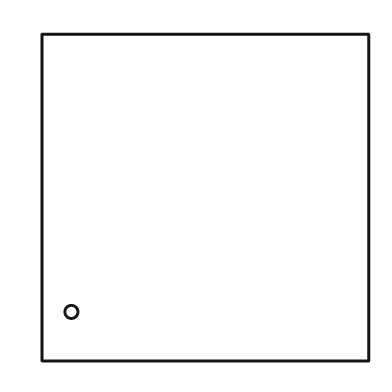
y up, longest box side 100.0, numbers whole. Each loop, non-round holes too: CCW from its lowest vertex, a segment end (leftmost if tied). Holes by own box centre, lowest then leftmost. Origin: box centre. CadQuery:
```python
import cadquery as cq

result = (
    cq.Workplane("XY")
    .moveTo(-50.0, -50.0)
    .lineTo(50.0, -50.0)
    .lineTo(50.0, 50.0)
    .lineTo(-50.0, 50.0)
    .close()
    .moveTo(-41.0, -35.0)
    .circle(2.0)
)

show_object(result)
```